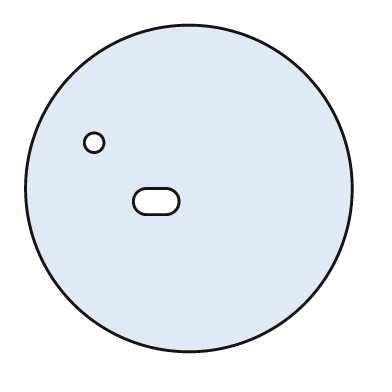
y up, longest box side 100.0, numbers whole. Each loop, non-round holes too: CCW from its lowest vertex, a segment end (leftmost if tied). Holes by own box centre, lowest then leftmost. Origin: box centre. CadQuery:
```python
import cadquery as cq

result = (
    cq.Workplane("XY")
    .moveTo(0.0, 0.0)
    .circle(50.0)
    .moveTo(-13.0, -8.0)
    .lineTo(-7.0, -8.0)
    .threePointArc((-3.0, -4.0), (-7.0, 0.0))
    .lineTo(-13.0, 0.0)
    .threePointArc((-17.0, -4.0), (-13.0, -8.0))
    .close()
    .moveTo(-29.0, 14.0)
    .circle(3.0)
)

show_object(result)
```